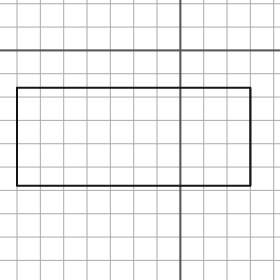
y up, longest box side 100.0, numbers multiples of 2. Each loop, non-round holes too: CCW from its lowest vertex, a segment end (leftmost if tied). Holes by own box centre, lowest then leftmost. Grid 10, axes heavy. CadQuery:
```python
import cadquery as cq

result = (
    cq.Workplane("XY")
    .moveTo(-70.0, -58.0)
    .lineTo(30.0, -58.0)
    .lineTo(30.0, -16.0)
    .lineTo(-70.0, -16.0)
    .close()
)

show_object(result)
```